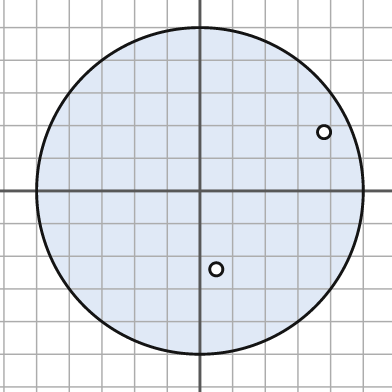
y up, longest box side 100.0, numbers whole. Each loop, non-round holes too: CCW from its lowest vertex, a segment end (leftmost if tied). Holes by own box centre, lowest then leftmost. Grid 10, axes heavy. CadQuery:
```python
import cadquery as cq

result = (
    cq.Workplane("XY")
    .moveTo(0.0, 0.0)
    .circle(50.0)
    .moveTo(5.0, -24.0)
    .circle(2.0)
    .moveTo(38.0, 18.0)
    .circle(2.0)
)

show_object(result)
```